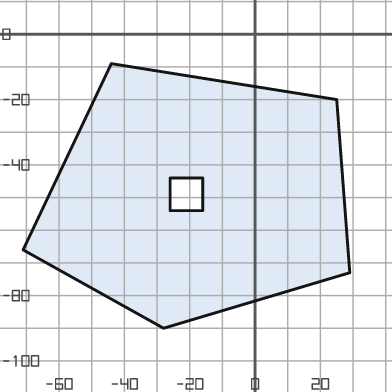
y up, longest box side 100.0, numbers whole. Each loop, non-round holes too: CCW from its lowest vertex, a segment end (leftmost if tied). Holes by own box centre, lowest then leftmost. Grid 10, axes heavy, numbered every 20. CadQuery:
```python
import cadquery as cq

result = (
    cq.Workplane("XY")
    .moveTo(-28.0, -90.0)
    .lineTo(29.0, -73.0)
    .lineTo(25.0, -20.0)
    .lineTo(-44.0, -9.0)
    .lineTo(-71.0, -66.0)
    .close()
    .moveTo(-26.0, -54.0)
    .lineTo(-16.0, -54.0)
    .lineTo(-16.0, -44.0)
    .lineTo(-26.0, -44.0)
    .close()
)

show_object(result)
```